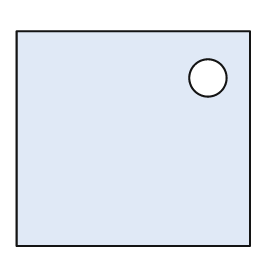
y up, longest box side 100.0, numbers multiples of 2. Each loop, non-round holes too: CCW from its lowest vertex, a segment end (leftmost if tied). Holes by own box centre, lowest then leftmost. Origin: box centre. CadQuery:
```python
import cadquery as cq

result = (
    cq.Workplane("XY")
    .moveTo(-50.0, -46.0)
    .lineTo(50.0, -46.0)
    .lineTo(50.0, 46.0)
    .lineTo(-50.0, 46.0)
    .close()
    .moveTo(32.0, 26.0)
    .circle(8.0)
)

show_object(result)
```